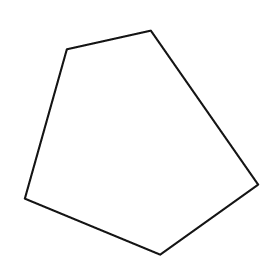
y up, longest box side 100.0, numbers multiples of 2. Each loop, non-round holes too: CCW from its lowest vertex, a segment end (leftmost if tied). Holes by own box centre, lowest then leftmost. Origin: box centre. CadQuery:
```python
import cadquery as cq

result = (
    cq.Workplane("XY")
    .moveTo(8.0, -48.0)
    .lineTo(50.0, -18.0)
    .lineTo(4.0, 48.0)
    .lineTo(-32.0, 40.0)
    .lineTo(-50.0, -24.0)
    .close()
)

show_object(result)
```